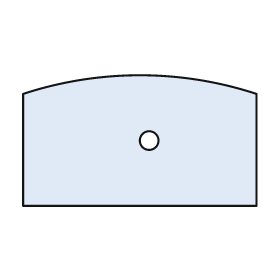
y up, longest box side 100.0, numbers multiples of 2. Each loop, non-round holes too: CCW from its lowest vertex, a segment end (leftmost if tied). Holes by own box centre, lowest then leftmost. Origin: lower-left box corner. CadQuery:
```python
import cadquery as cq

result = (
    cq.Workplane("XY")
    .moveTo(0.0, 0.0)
    .lineTo(100.0, 0.0)
    .lineTo(100.0, 48.0)
    .threePointArc((50.0, 56.0), (0.0, 48.0))
    .close()
    .moveTo(54.0, 28.0)
    .circle(4.0)
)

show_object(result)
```